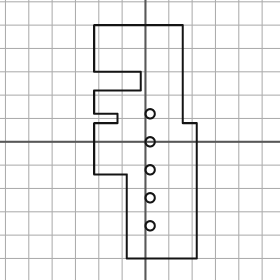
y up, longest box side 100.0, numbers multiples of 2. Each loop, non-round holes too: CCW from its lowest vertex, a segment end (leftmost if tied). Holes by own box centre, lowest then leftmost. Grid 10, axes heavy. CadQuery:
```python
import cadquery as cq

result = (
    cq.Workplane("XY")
    .moveTo(-8.0, -50.0)
    .lineTo(22.0, -50.0)
    .lineTo(22.0, 8.0)
    .lineTo(16.0, 8.0)
    .lineTo(16.0, 50.0)
    .lineTo(-22.0, 50.0)
    .lineTo(-22.0, 30.0)
    .lineTo(-2.0, 30.0)
    .lineTo(-2.0, 22.0)
    .lineTo(-22.0, 22.0)
    .lineTo(-22.0, 12.0)
    .lineTo(-12.0, 12.0)
    .lineTo(-12.0, 8.0)
    .lineTo(-22.0, 8.0)
    .lineTo(-22.0, -14.0)
    .lineTo(-8.0, -14.0)
    .close()
    .moveTo(2.0, -36.0)
    .circle(2.0)
    .moveTo(2.0, -24.0)
    .circle(2.0)
    .moveTo(2.0, -12.0)
    .circle(2.0)
    .moveTo(2.0, 0.0)
    .circle(2.0)
    .moveTo(2.0, 12.0)
    .circle(2.0)
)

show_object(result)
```